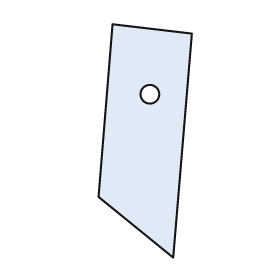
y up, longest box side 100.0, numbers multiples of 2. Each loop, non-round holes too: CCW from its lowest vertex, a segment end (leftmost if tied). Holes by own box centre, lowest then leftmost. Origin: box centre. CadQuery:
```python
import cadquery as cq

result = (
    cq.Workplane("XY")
    .moveTo(12.0, -50.0)
    .lineTo(20.0, 46.0)
    .lineTo(-14.0, 50.0)
    .lineTo(-20.0, -24.0)
    .close()
    .moveTo(2.0, 20.0)
    .circle(4.0)
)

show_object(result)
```